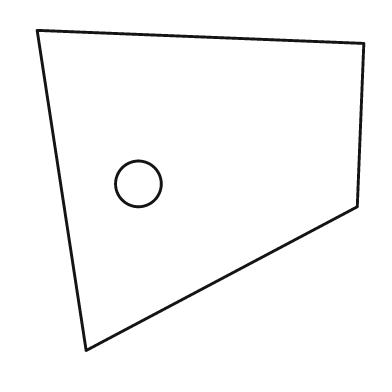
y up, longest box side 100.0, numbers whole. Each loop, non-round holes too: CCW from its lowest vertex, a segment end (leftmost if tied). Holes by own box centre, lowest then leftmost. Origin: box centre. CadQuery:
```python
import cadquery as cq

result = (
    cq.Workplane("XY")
    .moveTo(-35.0, -49.0)
    .lineTo(48.0, -5.0)
    .lineTo(50.0, 45.0)
    .lineTo(-50.0, 49.0)
    .close()
    .moveTo(-19.0, 2.0)
    .circle(7.0)
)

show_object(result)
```